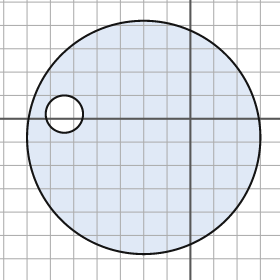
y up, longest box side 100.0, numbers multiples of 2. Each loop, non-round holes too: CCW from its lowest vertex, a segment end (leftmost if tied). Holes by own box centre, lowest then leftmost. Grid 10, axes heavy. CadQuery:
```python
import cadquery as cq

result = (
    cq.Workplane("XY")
    .moveTo(-20.0, -8.0)
    .circle(50.0)
    .moveTo(-54.0, 2.0)
    .circle(8.0)
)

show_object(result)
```